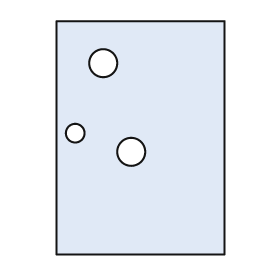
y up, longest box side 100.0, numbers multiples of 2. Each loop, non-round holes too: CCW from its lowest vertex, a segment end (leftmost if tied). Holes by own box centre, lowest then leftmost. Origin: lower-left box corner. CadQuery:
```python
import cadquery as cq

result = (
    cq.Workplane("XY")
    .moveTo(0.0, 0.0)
    .lineTo(72.0, 0.0)
    .lineTo(72.0, 100.0)
    .lineTo(0.0, 100.0)
    .close()
    .moveTo(32.0, 44.0)
    .circle(6.0)
    .moveTo(8.0, 52.0)
    .circle(4.0)
    .moveTo(20.0, 82.0)
    .circle(6.0)
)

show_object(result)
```